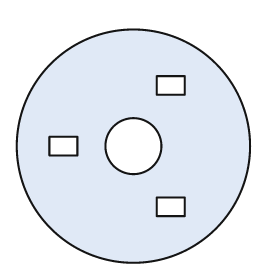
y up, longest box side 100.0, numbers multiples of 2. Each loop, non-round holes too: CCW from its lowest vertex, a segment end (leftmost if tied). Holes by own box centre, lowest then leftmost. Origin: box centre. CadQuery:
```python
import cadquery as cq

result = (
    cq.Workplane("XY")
    .moveTo(0.0, 0.0)
    .circle(50.0)
    .moveTo(10.0, -30.0)
    .lineTo(22.0, -30.0)
    .lineTo(22.0, -22.0)
    .lineTo(10.0, -22.0)
    .close()
    .moveTo(-36.0, -4.0)
    .lineTo(-24.0, -4.0)
    .lineTo(-24.0, 4.0)
    .lineTo(-36.0, 4.0)
    .close()
    .moveTo(0.0, 0.0)
    .circle(12.0)
    .moveTo(10.0, 22.0)
    .lineTo(22.0, 22.0)
    .lineTo(22.0, 30.0)
    .lineTo(10.0, 30.0)
    .close()
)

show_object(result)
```